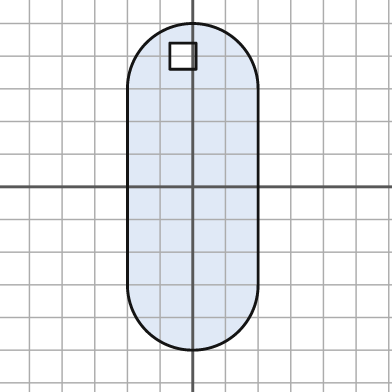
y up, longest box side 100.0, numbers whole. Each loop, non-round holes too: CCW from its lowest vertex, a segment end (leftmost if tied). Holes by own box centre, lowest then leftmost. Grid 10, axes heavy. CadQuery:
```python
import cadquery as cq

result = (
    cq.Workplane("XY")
    .moveTo(-20.0, -30.0)
    .threePointArc((0.0, -50.0), (20.0, -30.0))
    .lineTo(20.0, 30.0)
    .threePointArc((0.0, 50.0), (-20.0, 30.0))
    .close()
    .moveTo(-7.0, 36.0)
    .lineTo(1.0, 36.0)
    .lineTo(1.0, 44.0)
    .lineTo(-7.0, 44.0)
    .close()
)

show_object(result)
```